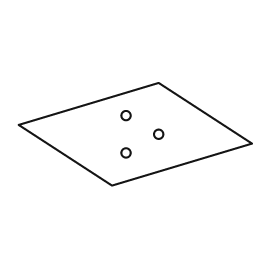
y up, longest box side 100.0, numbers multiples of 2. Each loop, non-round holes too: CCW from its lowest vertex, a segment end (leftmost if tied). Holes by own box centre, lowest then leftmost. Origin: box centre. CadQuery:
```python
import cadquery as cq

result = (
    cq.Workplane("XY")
    .moveTo(-10.0, -22.0)
    .lineTo(50.0, -4.0)
    .lineTo(10.0, 22.0)
    .lineTo(-50.0, 4.0)
    .close()
    .moveTo(-4.0, -8.0)
    .circle(2.0)
    .moveTo(10.0, 0.0)
    .circle(2.0)
    .moveTo(-4.0, 8.0)
    .circle(2.0)
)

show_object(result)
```